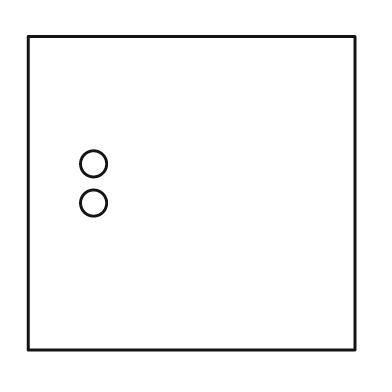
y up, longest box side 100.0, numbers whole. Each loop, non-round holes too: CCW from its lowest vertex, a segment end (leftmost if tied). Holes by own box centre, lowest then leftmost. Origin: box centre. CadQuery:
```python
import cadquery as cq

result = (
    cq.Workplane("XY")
    .moveTo(-50.0, -48.0)
    .lineTo(50.0, -48.0)
    .lineTo(50.0, 48.0)
    .lineTo(-50.0, 48.0)
    .close()
    .moveTo(-30.0, -3.0)
    .circle(4.0)
    .moveTo(-30.0, 9.0)
    .circle(4.0)
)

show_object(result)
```